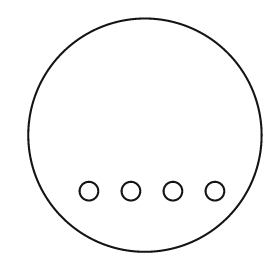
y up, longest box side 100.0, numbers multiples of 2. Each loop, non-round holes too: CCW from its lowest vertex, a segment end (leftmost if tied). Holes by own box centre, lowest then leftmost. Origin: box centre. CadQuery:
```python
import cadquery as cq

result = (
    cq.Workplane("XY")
    .moveTo(0.0, 0.0)
    .circle(50.0)
    .moveTo(-24.0, -24.0)
    .circle(4.0)
    .moveTo(-6.0, -24.0)
    .circle(4.0)
    .moveTo(12.0, -24.0)
    .circle(4.0)
    .moveTo(30.0, -24.0)
    .circle(4.0)
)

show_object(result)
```